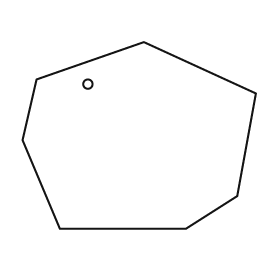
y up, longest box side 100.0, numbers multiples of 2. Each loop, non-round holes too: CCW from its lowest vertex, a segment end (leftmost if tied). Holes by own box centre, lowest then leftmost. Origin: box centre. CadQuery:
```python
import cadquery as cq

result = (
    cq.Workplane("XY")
    .moveTo(-34.0, -40.0)
    .lineTo(20.0, -40.0)
    .lineTo(42.0, -26.0)
    .lineTo(50.0, 18.0)
    .lineTo(2.0, 40.0)
    .lineTo(-44.0, 24.0)
    .lineTo(-50.0, -2.0)
    .close()
    .moveTo(-22.0, 22.0)
    .circle(2.0)
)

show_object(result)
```